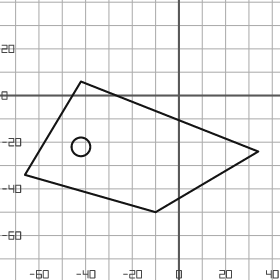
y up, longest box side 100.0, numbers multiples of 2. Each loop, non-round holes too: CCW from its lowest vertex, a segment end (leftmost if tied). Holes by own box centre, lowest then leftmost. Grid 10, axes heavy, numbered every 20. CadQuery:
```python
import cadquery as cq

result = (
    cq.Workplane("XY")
    .moveTo(-10.0, -50.0)
    .lineTo(34.0, -24.0)
    .lineTo(-42.0, 6.0)
    .lineTo(-66.0, -34.0)
    .close()
    .moveTo(-42.0, -22.0)
    .circle(4.0)
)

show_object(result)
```